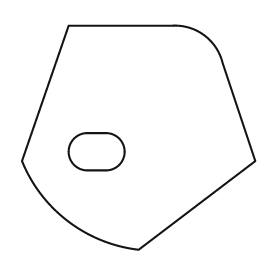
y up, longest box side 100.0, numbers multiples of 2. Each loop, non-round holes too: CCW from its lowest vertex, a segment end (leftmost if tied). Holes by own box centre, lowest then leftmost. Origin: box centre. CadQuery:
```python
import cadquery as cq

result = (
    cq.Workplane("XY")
    .moveTo(0.0, -48.0)
    .lineTo(50.0, -10.0)
    .lineTo(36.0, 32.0)
    .threePointArc((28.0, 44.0), (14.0, 48.0))
    .lineTo(-30.0, 48.0)
    .lineTo(-50.0, -10.0)
    .threePointArc((-30.0, -36.0), (0.0, -48.0))
    .close()
    .moveTo(-22.0, -14.0)
    .lineTo(-14.0, -14.0)
    .threePointArc((-6.0, -6.0), (-14.0, 2.0))
    .lineTo(-22.0, 2.0)
    .threePointArc((-30.0, -6.0), (-22.0, -14.0))
    .close()
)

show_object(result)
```